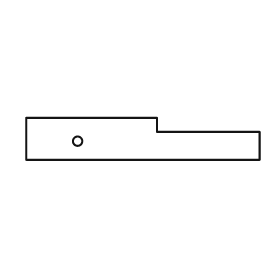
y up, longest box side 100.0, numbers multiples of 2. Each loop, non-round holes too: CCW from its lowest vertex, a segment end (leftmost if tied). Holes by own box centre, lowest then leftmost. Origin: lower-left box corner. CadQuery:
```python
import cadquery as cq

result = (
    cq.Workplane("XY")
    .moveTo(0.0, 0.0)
    .lineTo(100.0, 0.0)
    .lineTo(100.0, 12.0)
    .lineTo(56.0, 12.0)
    .lineTo(56.0, 18.0)
    .lineTo(0.0, 18.0)
    .close()
    .moveTo(22.0, 8.0)
    .circle(2.0)
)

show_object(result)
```